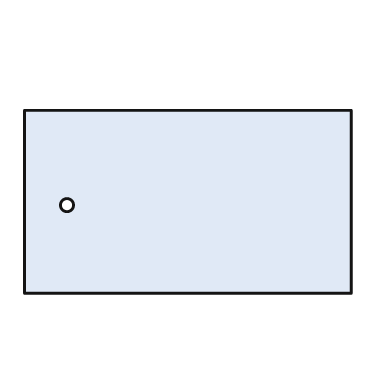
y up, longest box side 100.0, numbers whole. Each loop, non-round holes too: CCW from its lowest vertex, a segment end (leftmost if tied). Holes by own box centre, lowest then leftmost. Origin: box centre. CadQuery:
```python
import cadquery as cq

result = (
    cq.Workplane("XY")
    .moveTo(-50.0, -28.0)
    .lineTo(50.0, -28.0)
    .lineTo(50.0, 28.0)
    .lineTo(-50.0, 28.0)
    .close()
    .moveTo(-37.0, -1.0)
    .circle(2.0)
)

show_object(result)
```